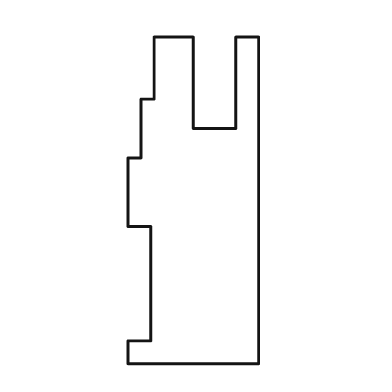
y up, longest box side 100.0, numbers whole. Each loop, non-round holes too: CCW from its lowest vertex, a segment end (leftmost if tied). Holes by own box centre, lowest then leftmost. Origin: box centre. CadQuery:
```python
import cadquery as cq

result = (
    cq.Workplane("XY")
    .moveTo(-20.0, -50.0)
    .lineTo(20.0, -50.0)
    .lineTo(20.0, 50.0)
    .lineTo(13.0, 50.0)
    .lineTo(13.0, 22.0)
    .lineTo(0.0, 22.0)
    .lineTo(0.0, 50.0)
    .lineTo(-12.0, 50.0)
    .lineTo(-12.0, 31.0)
    .lineTo(-16.0, 31.0)
    .lineTo(-16.0, 13.0)
    .lineTo(-20.0, 13.0)
    .lineTo(-20.0, -8.0)
    .lineTo(-13.0, -8.0)
    .lineTo(-13.0, -43.0)
    .lineTo(-20.0, -43.0)
    .close()
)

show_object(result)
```